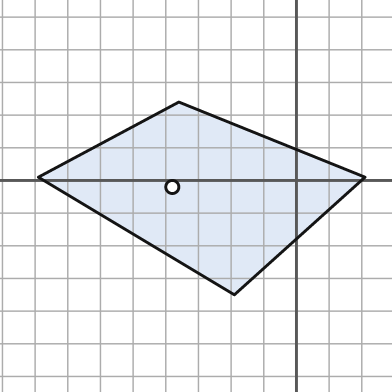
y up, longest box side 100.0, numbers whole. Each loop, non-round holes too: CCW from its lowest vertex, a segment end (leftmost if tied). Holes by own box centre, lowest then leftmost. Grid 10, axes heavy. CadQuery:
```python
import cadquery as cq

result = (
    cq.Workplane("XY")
    .moveTo(-19.0, -35.0)
    .lineTo(21.0, 1.0)
    .lineTo(-36.0, 24.0)
    .lineTo(-79.0, 1.0)
    .close()
    .moveTo(-38.0, -2.0)
    .circle(2.0)
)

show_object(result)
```